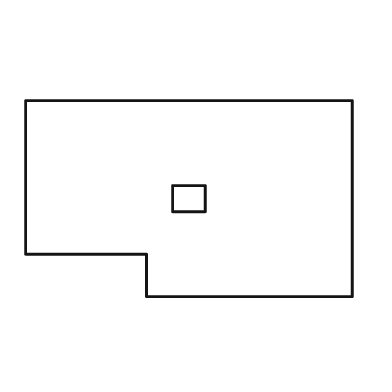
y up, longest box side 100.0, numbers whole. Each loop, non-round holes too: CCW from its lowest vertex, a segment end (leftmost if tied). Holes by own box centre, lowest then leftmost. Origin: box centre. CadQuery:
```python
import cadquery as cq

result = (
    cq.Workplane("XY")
    .moveTo(-13.0, -30.0)
    .lineTo(50.0, -30.0)
    .lineTo(50.0, 30.0)
    .lineTo(-50.0, 30.0)
    .lineTo(-50.0, -17.0)
    .lineTo(-13.0, -17.0)
    .close()
    .moveTo(-5.0, -4.0)
    .lineTo(5.0, -4.0)
    .lineTo(5.0, 4.0)
    .lineTo(-5.0, 4.0)
    .close()
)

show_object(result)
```